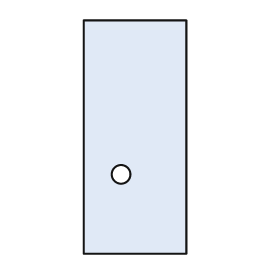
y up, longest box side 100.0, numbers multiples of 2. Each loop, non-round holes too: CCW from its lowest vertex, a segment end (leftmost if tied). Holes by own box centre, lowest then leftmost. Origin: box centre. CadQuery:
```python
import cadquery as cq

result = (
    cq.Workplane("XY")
    .moveTo(-22.0, -50.0)
    .lineTo(22.0, -50.0)
    .lineTo(22.0, 50.0)
    .lineTo(-22.0, 50.0)
    .close()
    .moveTo(-6.0, -16.0)
    .circle(4.0)
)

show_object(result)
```